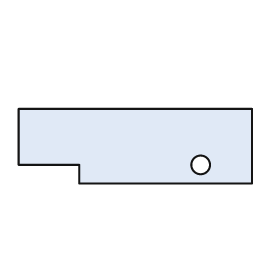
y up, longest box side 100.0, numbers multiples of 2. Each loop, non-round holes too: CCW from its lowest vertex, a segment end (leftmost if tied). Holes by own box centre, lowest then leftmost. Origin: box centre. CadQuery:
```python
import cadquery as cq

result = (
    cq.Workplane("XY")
    .moveTo(-24.0, -16.0)
    .lineTo(50.0, -16.0)
    .lineTo(50.0, 16.0)
    .lineTo(-50.0, 16.0)
    .lineTo(-50.0, -8.0)
    .lineTo(-24.0, -8.0)
    .close()
    .moveTo(28.0, -8.0)
    .circle(4.0)
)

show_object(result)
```